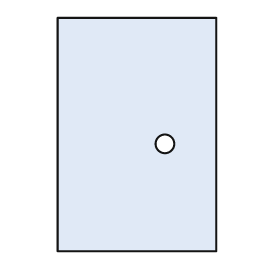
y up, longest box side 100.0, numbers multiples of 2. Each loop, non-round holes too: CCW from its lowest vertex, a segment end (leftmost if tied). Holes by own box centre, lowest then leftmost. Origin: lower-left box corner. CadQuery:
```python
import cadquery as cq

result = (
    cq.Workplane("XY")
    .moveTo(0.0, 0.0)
    .lineTo(68.0, 0.0)
    .lineTo(68.0, 100.0)
    .lineTo(0.0, 100.0)
    .close()
    .moveTo(46.0, 46.0)
    .circle(4.0)
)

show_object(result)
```